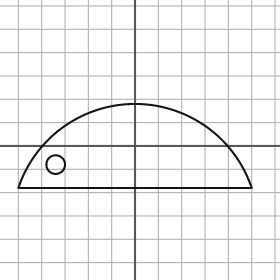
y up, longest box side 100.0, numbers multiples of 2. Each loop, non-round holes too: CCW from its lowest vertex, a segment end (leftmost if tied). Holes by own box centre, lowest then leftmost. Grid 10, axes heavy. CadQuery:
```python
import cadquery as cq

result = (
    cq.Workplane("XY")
    .moveTo(-50.0, -18.0)
    .lineTo(50.0, -18.0)
    .threePointArc((0.0, 18.0), (-50.0, -18.0))
    .close()
    .moveTo(-34.0, -8.0)
    .circle(4.0)
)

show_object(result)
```